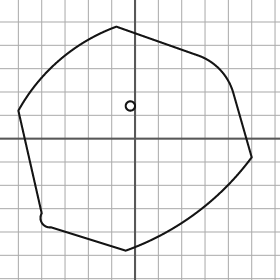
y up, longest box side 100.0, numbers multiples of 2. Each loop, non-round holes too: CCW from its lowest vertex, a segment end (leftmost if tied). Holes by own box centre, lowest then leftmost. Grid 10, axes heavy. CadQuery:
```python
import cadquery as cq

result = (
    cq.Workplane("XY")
    .moveTo(-4.0, -48.0)
    .threePointArc((26.0, -32.0), (50.0, -8.0))
    .lineTo(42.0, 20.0)
    .threePointArc((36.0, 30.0), (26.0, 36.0))
    .lineTo(-8.0, 48.0)
    .threePointArc((-32.0, 34.0), (-50.0, 12.0))
    .lineTo(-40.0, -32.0)
    .threePointArc((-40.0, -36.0), (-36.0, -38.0))
    .close()
    .moveTo(-2.0, 14.0)
    .circle(2.0)
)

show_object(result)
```